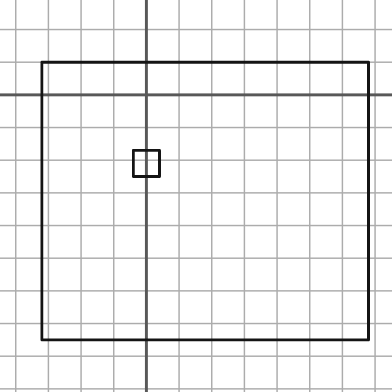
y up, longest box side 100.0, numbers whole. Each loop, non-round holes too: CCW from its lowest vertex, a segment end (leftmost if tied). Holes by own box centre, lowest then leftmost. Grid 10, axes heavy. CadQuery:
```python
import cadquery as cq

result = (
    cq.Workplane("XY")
    .moveTo(-32.0, -75.0)
    .lineTo(68.0, -75.0)
    .lineTo(68.0, 10.0)
    .lineTo(-32.0, 10.0)
    .close()
    .moveTo(-4.0, -25.0)
    .lineTo(4.0, -25.0)
    .lineTo(4.0, -17.0)
    .lineTo(-4.0, -17.0)
    .close()
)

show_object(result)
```